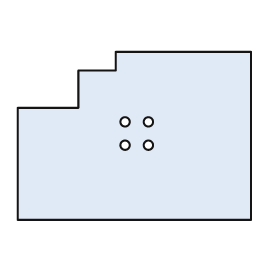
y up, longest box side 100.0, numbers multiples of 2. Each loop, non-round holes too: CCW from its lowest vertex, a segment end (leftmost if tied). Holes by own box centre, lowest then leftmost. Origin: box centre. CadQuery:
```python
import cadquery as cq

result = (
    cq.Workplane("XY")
    .moveTo(-50.0, -36.0)
    .lineTo(50.0, -36.0)
    .lineTo(50.0, 36.0)
    .lineTo(-8.0, 36.0)
    .lineTo(-8.0, 28.0)
    .lineTo(-24.0, 28.0)
    .lineTo(-24.0, 12.0)
    .lineTo(-50.0, 12.0)
    .close()
    .moveTo(-4.0, -4.0)
    .circle(2.0)
    .moveTo(6.0, -4.0)
    .circle(2.0)
    .moveTo(-4.0, 6.0)
    .circle(2.0)
    .moveTo(6.0, 6.0)
    .circle(2.0)
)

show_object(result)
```